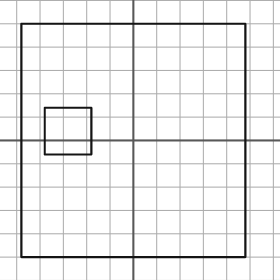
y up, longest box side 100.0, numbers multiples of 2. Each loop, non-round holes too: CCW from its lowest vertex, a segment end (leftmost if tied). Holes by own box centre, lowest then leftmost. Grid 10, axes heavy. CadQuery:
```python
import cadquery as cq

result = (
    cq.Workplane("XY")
    .moveTo(-48.0, -50.0)
    .lineTo(48.0, -50.0)
    .lineTo(48.0, 50.0)
    .lineTo(-48.0, 50.0)
    .close()
    .moveTo(-38.0, -6.0)
    .lineTo(-18.0, -6.0)
    .lineTo(-18.0, 14.0)
    .lineTo(-38.0, 14.0)
    .close()
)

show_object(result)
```